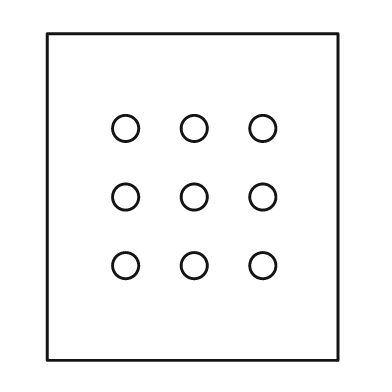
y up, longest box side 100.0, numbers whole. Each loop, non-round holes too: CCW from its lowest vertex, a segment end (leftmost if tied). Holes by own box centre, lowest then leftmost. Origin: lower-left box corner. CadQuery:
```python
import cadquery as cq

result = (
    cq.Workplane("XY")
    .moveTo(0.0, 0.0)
    .lineTo(89.0, 0.0)
    .lineTo(89.0, 100.0)
    .lineTo(0.0, 100.0)
    .close()
    .moveTo(24.0, 29.0)
    .circle(4.0)
    .moveTo(45.0, 29.0)
    .circle(4.0)
    .moveTo(66.0, 29.0)
    .circle(4.0)
    .moveTo(24.0, 50.0)
    .circle(4.0)
    .moveTo(45.0, 50.0)
    .circle(4.0)
    .moveTo(66.0, 50.0)
    .circle(4.0)
    .moveTo(24.0, 71.0)
    .circle(4.0)
    .moveTo(45.0, 71.0)
    .circle(4.0)
    .moveTo(66.0, 71.0)
    .circle(4.0)
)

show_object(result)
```